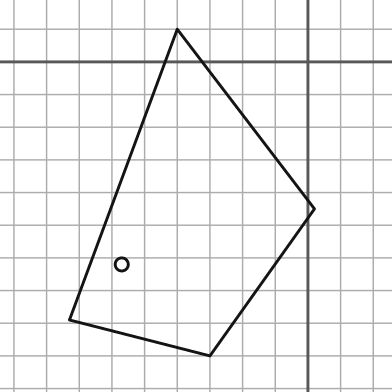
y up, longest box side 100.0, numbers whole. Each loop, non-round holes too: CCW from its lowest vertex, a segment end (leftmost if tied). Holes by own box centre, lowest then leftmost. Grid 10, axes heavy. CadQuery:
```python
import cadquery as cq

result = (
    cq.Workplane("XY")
    .moveTo(-30.0, -90.0)
    .lineTo(2.0, -45.0)
    .lineTo(-40.0, 10.0)
    .lineTo(-73.0, -79.0)
    .close()
    .moveTo(-57.0, -62.0)
    .circle(2.0)
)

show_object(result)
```